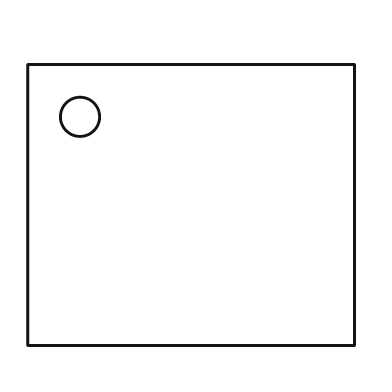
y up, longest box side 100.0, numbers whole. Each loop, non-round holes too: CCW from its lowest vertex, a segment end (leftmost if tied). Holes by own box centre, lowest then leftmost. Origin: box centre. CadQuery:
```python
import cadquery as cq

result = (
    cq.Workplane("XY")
    .moveTo(-50.0, -43.0)
    .lineTo(50.0, -43.0)
    .lineTo(50.0, 43.0)
    .lineTo(-50.0, 43.0)
    .close()
    .moveTo(-34.0, 27.0)
    .circle(6.0)
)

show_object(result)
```